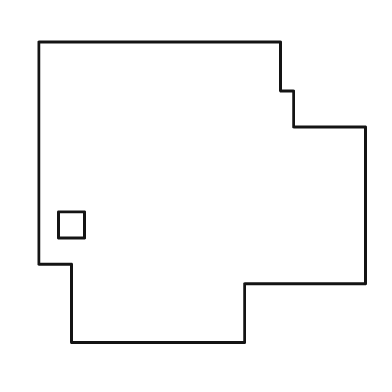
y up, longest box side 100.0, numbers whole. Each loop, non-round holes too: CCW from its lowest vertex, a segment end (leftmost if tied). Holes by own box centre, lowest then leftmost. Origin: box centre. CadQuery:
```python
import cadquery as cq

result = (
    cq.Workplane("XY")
    .moveTo(-40.0, -46.0)
    .lineTo(13.0, -46.0)
    .lineTo(13.0, -28.0)
    .lineTo(50.0, -28.0)
    .lineTo(50.0, 20.0)
    .lineTo(28.0, 20.0)
    .lineTo(28.0, 31.0)
    .lineTo(24.0, 31.0)
    .lineTo(24.0, 46.0)
    .lineTo(-50.0, 46.0)
    .lineTo(-50.0, -22.0)
    .lineTo(-40.0, -22.0)
    .close()
    .moveTo(-44.0, -14.0)
    .lineTo(-36.0, -14.0)
    .lineTo(-36.0, -6.0)
    .lineTo(-44.0, -6.0)
    .close()
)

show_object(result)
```